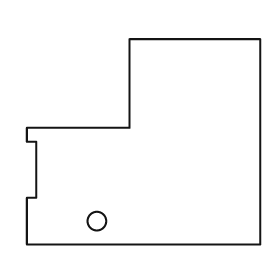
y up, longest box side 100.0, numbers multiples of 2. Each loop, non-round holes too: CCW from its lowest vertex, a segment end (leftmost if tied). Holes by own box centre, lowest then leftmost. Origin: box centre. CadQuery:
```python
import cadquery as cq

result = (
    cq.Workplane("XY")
    .moveTo(-50.0, -44.0)
    .lineTo(50.0, -44.0)
    .lineTo(50.0, 44.0)
    .lineTo(-6.0, 44.0)
    .lineTo(-6.0, 6.0)
    .lineTo(-50.0, 6.0)
    .lineTo(-50.0, 0.0)
    .lineTo(-46.0, 0.0)
    .lineTo(-46.0, -24.0)
    .lineTo(-50.0, -24.0)
    .close()
    .moveTo(-20.0, -34.0)
    .circle(4.0)
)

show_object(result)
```